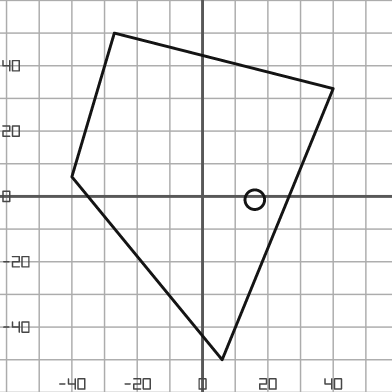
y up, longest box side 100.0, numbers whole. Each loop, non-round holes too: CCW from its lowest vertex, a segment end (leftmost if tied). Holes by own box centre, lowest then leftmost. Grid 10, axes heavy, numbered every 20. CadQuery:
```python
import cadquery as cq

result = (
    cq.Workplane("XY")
    .moveTo(6.0, -50.0)
    .lineTo(40.0, 33.0)
    .lineTo(-27.0, 50.0)
    .lineTo(-40.0, 6.0)
    .close()
    .moveTo(16.0, -1.0)
    .circle(3.0)
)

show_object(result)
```